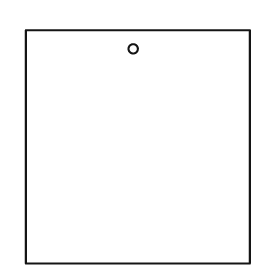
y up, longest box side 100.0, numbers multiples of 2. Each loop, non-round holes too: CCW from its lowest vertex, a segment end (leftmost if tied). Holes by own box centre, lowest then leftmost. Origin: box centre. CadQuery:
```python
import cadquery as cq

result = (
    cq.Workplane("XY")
    .moveTo(-48.0, -50.0)
    .lineTo(48.0, -50.0)
    .lineTo(48.0, 50.0)
    .lineTo(-48.0, 50.0)
    .close()
    .moveTo(-2.0, 42.0)
    .circle(2.0)
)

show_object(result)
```